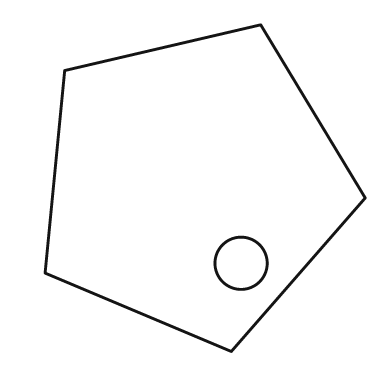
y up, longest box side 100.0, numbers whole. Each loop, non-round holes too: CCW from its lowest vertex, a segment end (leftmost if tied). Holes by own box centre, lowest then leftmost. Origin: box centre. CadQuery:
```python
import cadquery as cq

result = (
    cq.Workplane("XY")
    .moveTo(8.0, -50.0)
    .lineTo(49.0, -3.0)
    .lineTo(17.0, 50.0)
    .lineTo(-43.0, 36.0)
    .lineTo(-49.0, -26.0)
    .close()
    .moveTo(11.0, -23.0)
    .circle(8.0)
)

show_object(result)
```